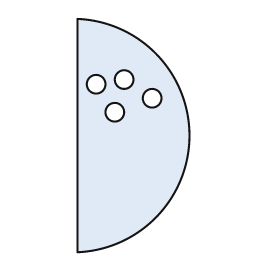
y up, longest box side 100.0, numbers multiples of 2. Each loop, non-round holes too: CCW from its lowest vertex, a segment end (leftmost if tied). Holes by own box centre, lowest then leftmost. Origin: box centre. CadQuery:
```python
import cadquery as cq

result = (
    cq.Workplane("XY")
    .moveTo(-24.0, -50.0)
    .threePointArc((24.0, 0.0), (-24.0, 50.0))
    .close()
    .moveTo(-8.0, 10.0)
    .circle(4.0)
    .moveTo(8.0, 16.0)
    .circle(4.0)
    .moveTo(-16.0, 22.0)
    .circle(4.0)
    .moveTo(-4.0, 24.0)
    .circle(4.0)
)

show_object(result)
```